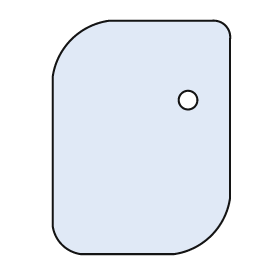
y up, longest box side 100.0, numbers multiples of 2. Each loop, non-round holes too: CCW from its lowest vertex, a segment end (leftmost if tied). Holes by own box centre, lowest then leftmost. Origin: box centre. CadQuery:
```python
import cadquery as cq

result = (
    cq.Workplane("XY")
    .moveTo(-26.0, -50.0)
    .lineTo(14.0, -50.0)
    .threePointArc((30.0, -42.0), (38.0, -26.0))
    .lineTo(38.0, 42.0)
    .threePointArc((36.0, 48.0), (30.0, 50.0))
    .lineTo(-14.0, 50.0)
    .threePointArc((-30.0, 42.0), (-38.0, 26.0))
    .lineTo(-38.0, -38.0)
    .threePointArc((-34.0, -46.0), (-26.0, -50.0))
    .close()
    .moveTo(20.0, 16.0)
    .circle(4.0)
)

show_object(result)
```